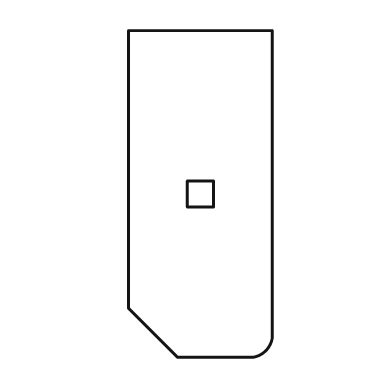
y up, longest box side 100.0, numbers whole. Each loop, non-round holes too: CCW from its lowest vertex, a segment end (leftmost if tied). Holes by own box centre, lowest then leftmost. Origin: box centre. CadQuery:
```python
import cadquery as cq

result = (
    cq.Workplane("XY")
    .moveTo(-7.0, -50.0)
    .lineTo(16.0, -50.0)
    .threePointArc((20.0, -48.0), (22.0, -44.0))
    .lineTo(22.0, 50.0)
    .lineTo(-22.0, 50.0)
    .lineTo(-22.0, -35.0)
    .close()
    .moveTo(-4.0, -4.0)
    .lineTo(4.0, -4.0)
    .lineTo(4.0, 4.0)
    .lineTo(-4.0, 4.0)
    .close()
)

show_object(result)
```